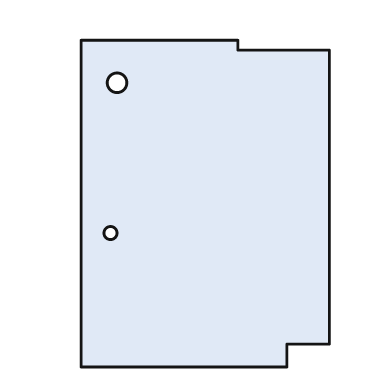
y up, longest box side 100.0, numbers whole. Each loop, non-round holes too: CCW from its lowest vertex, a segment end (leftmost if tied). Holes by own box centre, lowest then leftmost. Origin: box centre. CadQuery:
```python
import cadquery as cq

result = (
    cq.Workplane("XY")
    .moveTo(-38.0, -50.0)
    .lineTo(25.0, -50.0)
    .lineTo(25.0, -43.0)
    .lineTo(38.0, -43.0)
    .lineTo(38.0, 47.0)
    .lineTo(10.0, 47.0)
    .lineTo(10.0, 50.0)
    .lineTo(-38.0, 50.0)
    .close()
    .moveTo(-29.0, -9.0)
    .circle(2.0)
    .moveTo(-27.0, 37.0)
    .circle(3.0)
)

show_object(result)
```